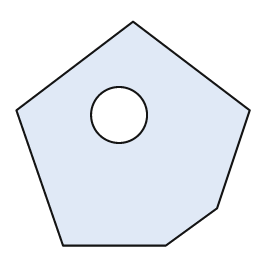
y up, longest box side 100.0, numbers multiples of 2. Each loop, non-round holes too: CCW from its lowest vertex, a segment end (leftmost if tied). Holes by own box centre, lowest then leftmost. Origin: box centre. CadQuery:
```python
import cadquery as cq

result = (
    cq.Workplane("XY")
    .moveTo(-30.0, -48.0)
    .lineTo(14.0, -48.0)
    .lineTo(36.0, -32.0)
    .lineTo(50.0, 10.0)
    .lineTo(0.0, 48.0)
    .lineTo(-50.0, 10.0)
    .close()
    .moveTo(-6.0, 8.0)
    .circle(12.0)
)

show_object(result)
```